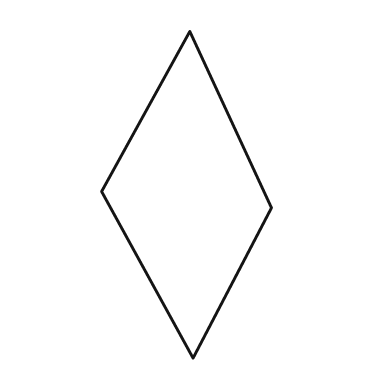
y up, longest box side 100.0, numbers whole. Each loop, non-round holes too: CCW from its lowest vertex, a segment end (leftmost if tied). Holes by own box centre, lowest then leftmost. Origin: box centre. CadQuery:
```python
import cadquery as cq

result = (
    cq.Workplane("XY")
    .moveTo(2.0, -50.0)
    .lineTo(26.0, -4.0)
    .lineTo(1.0, 50.0)
    .lineTo(-26.0, 1.0)
    .close()
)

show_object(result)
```